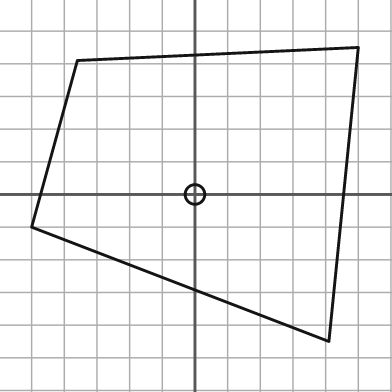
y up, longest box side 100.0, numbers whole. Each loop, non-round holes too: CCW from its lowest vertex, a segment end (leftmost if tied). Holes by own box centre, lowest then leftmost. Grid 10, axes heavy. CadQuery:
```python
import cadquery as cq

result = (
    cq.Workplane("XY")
    .moveTo(41.0, -45.0)
    .lineTo(50.0, 45.0)
    .lineTo(-36.0, 41.0)
    .lineTo(-50.0, -10.0)
    .close()
    .moveTo(0.0, 0.0)
    .circle(3.0)
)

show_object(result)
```